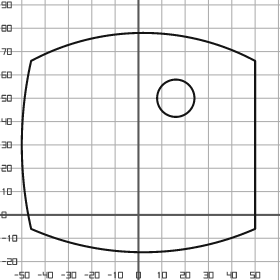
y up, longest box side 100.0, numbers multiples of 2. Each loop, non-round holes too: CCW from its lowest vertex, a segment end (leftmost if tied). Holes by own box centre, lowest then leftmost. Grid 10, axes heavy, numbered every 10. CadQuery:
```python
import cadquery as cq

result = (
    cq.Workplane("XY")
    .moveTo(-46.0, -6.0)
    .threePointArc((2.0, -16.0), (50.0, -6.0))
    .lineTo(50.0, 66.0)
    .threePointArc((2.0, 78.0), (-46.0, 66.0))
    .threePointArc((-50.0, 30.0), (-46.0, -6.0))
    .close()
    .moveTo(16.0, 50.0)
    .circle(8.0)
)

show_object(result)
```